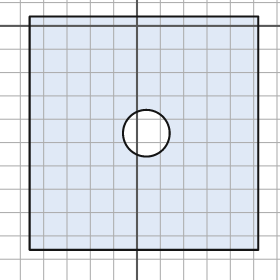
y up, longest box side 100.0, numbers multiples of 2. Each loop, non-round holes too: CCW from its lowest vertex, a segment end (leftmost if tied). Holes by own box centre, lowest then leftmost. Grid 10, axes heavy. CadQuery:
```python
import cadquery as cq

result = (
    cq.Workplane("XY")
    .moveTo(-46.0, -96.0)
    .lineTo(52.0, -96.0)
    .lineTo(52.0, 4.0)
    .lineTo(-46.0, 4.0)
    .close()
    .moveTo(4.0, -46.0)
    .circle(10.0)
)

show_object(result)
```